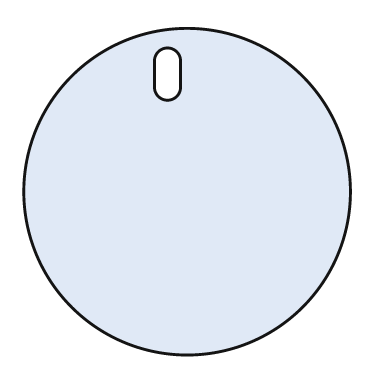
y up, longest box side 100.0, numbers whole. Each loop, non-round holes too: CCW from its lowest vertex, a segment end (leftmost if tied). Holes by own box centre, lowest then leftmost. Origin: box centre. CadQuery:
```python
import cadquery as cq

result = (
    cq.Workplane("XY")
    .moveTo(0.0, 0.0)
    .circle(50.0)
    .moveTo(-10.0, 32.0)
    .threePointArc((-6.0, 28.0), (-2.0, 32.0))
    .lineTo(-2.0, 40.0)
    .threePointArc((-6.0, 44.0), (-10.0, 40.0))
    .close()
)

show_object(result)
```